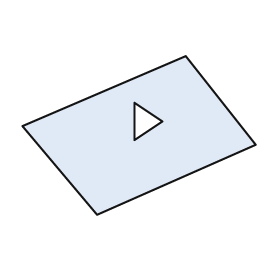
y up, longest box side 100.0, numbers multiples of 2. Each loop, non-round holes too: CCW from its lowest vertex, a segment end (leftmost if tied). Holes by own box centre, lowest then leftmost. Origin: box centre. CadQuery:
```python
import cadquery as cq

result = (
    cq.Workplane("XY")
    .moveTo(-18.0, -34.0)
    .lineTo(50.0, -4.0)
    .lineTo(20.0, 34.0)
    .lineTo(-50.0, 4.0)
    .close()
    .moveTo(-2.0, -2.0)
    .lineTo(10.0, 6.0)
    .lineTo(-2.0, 14.0)
    .close()
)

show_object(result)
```